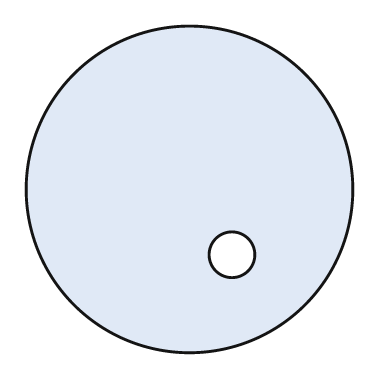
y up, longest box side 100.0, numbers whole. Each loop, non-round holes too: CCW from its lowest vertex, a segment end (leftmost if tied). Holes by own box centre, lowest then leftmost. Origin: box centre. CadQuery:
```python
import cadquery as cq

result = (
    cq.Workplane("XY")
    .moveTo(0.0, 0.0)
    .circle(50.0)
    .moveTo(13.0, -20.0)
    .circle(7.0)
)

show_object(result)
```